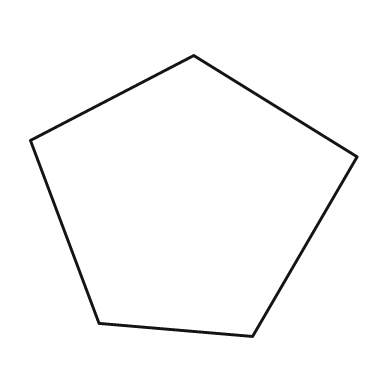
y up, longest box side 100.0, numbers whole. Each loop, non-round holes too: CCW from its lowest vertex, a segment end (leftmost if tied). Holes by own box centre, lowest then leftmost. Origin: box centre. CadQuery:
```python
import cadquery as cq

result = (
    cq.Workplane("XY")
    .moveTo(18.0, -43.0)
    .lineTo(50.0, 12.0)
    .lineTo(0.0, 43.0)
    .lineTo(-50.0, 17.0)
    .lineTo(-29.0, -39.0)
    .close()
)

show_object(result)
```